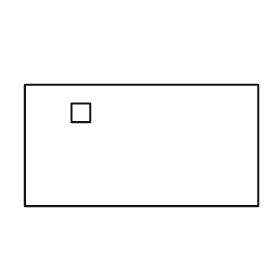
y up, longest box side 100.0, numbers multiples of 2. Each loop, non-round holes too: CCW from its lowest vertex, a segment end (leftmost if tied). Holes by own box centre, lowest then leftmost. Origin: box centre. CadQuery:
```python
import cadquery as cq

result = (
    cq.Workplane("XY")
    .moveTo(-50.0, -26.0)
    .lineTo(50.0, -26.0)
    .lineTo(50.0, 26.0)
    .lineTo(-50.0, 26.0)
    .close()
    .moveTo(-30.0, 10.0)
    .lineTo(-22.0, 10.0)
    .lineTo(-22.0, 18.0)
    .lineTo(-30.0, 18.0)
    .close()
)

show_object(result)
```